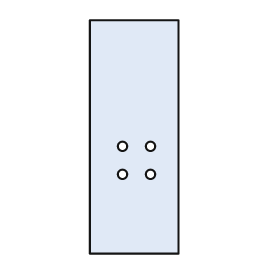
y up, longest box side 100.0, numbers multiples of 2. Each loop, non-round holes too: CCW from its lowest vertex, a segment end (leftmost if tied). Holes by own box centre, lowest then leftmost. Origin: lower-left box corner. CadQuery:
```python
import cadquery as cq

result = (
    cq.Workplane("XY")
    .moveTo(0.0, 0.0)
    .lineTo(38.0, 0.0)
    .lineTo(38.0, 100.0)
    .lineTo(0.0, 100.0)
    .close()
    .moveTo(14.0, 34.0)
    .circle(2.0)
    .moveTo(26.0, 34.0)
    .circle(2.0)
    .moveTo(14.0, 46.0)
    .circle(2.0)
    .moveTo(26.0, 46.0)
    .circle(2.0)
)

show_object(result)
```